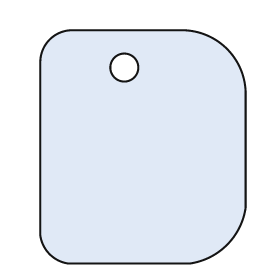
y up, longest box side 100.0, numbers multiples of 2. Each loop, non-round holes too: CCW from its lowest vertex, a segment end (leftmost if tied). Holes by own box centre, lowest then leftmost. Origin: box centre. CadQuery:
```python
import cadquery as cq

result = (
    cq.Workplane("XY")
    .moveTo(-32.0, -50.0)
    .lineTo(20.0, -50.0)
    .threePointArc((36.0, -42.0), (44.0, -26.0))
    .lineTo(44.0, 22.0)
    .threePointArc((36.0, 42.0), (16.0, 50.0))
    .lineTo(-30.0, 50.0)
    .threePointArc((-40.0, 46.0), (-44.0, 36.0))
    .lineTo(-44.0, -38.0)
    .threePointArc((-40.0, -46.0), (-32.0, -50.0))
    .close()
    .moveTo(-8.0, 34.0)
    .circle(6.0)
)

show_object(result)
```